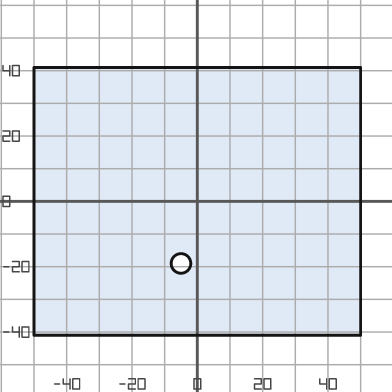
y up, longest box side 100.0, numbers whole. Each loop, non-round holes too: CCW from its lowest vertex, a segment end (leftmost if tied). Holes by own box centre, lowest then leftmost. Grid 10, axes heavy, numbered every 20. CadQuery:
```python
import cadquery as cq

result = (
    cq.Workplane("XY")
    .moveTo(-50.0, -41.0)
    .lineTo(50.0, -41.0)
    .lineTo(50.0, 41.0)
    .lineTo(-50.0, 41.0)
    .close()
    .moveTo(-5.0, -19.0)
    .circle(3.0)
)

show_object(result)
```